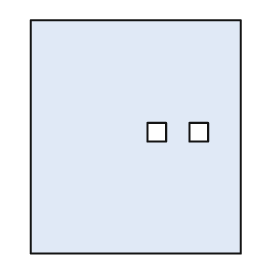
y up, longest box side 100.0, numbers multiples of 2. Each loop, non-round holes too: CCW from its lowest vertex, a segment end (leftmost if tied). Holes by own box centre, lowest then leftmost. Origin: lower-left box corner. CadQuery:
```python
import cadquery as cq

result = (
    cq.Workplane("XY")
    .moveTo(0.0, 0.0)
    .lineTo(90.0, 0.0)
    .lineTo(90.0, 100.0)
    .lineTo(0.0, 100.0)
    .close()
    .moveTo(50.0, 48.0)
    .lineTo(58.0, 48.0)
    .lineTo(58.0, 56.0)
    .lineTo(50.0, 56.0)
    .close()
    .moveTo(68.0, 48.0)
    .lineTo(76.0, 48.0)
    .lineTo(76.0, 56.0)
    .lineTo(68.0, 56.0)
    .close()
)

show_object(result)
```